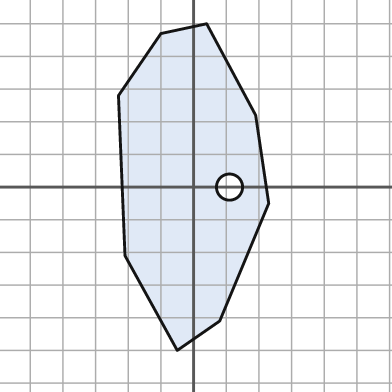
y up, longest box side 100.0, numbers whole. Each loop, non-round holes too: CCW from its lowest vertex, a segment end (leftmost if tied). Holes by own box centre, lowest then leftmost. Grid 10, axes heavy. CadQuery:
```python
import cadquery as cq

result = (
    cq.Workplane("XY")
    .moveTo(-5.0, -50.0)
    .lineTo(8.0, -41.0)
    .lineTo(23.0, -5.0)
    .lineTo(19.0, 22.0)
    .lineTo(4.0, 50.0)
    .lineTo(-10.0, 47.0)
    .lineTo(-23.0, 28.0)
    .lineTo(-21.0, -21.0)
    .close()
    .moveTo(11.0, 0.0)
    .circle(4.0)
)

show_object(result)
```